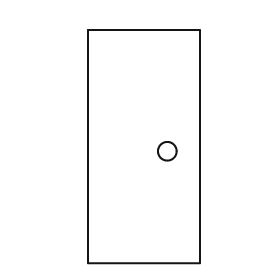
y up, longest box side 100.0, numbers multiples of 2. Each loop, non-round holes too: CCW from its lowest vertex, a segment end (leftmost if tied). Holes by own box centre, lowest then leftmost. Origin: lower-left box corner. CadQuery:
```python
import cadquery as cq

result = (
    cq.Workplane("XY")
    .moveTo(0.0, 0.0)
    .lineTo(48.0, 0.0)
    .lineTo(48.0, 100.0)
    .lineTo(0.0, 100.0)
    .close()
    .moveTo(34.0, 48.0)
    .circle(4.0)
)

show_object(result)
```